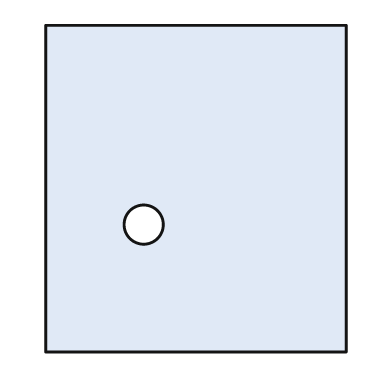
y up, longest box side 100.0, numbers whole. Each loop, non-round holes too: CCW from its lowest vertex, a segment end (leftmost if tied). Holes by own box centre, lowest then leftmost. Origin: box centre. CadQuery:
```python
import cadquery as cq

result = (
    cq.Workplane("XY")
    .moveTo(-46.0, -50.0)
    .lineTo(46.0, -50.0)
    .lineTo(46.0, 50.0)
    .lineTo(-46.0, 50.0)
    .close()
    .moveTo(-16.0, -11.0)
    .circle(6.0)
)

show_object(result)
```